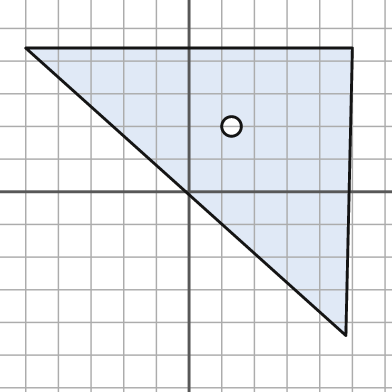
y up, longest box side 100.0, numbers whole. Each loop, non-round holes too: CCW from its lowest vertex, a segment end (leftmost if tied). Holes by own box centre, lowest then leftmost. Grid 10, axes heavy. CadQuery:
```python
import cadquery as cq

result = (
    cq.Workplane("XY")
    .moveTo(48.0, -44.0)
    .lineTo(50.0, 44.0)
    .lineTo(-50.0, 44.0)
    .close()
    .moveTo(13.0, 20.0)
    .circle(3.0)
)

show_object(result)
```